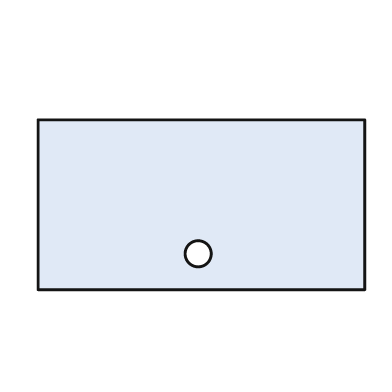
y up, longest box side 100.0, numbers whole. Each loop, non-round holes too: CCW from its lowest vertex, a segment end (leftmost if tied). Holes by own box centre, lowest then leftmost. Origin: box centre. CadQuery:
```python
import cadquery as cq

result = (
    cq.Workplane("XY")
    .moveTo(-50.0, -26.0)
    .lineTo(50.0, -26.0)
    .lineTo(50.0, 26.0)
    .lineTo(-50.0, 26.0)
    .close()
    .moveTo(-1.0, -15.0)
    .circle(4.0)
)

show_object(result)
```